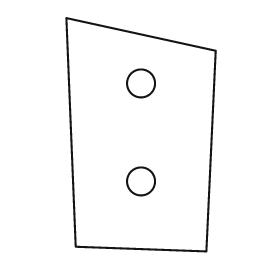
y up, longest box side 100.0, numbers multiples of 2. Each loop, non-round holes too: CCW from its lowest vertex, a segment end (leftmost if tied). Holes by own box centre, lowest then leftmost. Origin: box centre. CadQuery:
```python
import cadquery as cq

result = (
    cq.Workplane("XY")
    .moveTo(28.0, -50.0)
    .lineTo(32.0, 36.0)
    .lineTo(-32.0, 50.0)
    .lineTo(-28.0, -48.0)
    .close()
    .moveTo(0.0, -20.0)
    .circle(6.0)
    .moveTo(0.0, 22.0)
    .circle(6.0)
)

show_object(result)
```